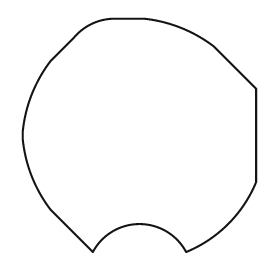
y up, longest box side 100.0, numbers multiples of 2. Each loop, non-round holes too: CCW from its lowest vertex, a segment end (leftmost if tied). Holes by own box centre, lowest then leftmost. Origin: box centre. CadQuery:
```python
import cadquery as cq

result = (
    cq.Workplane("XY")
    .moveTo(-20.0, -50.0)
    .threePointArc((0.0, -38.0), (20.0, -50.0))
    .threePointArc((38.0, -38.0), (50.0, -20.0))
    .lineTo(50.0, 20.0)
    .lineTo(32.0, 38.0)
    .threePointArc((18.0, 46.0), (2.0, 50.0))
    .lineTo(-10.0, 50.0)
    .threePointArc((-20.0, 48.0), (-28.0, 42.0))
    .lineTo(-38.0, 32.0)
    .threePointArc((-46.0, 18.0), (-50.0, 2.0))
    .lineTo(-50.0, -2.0)
    .threePointArc((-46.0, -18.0), (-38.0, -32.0))
    .close()
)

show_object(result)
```